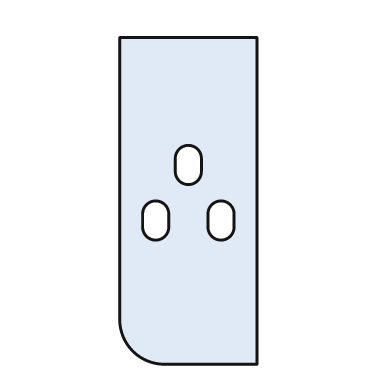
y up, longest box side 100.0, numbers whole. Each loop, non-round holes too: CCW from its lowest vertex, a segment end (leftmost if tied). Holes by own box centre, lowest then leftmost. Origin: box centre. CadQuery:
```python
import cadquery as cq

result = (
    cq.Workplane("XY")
    .moveTo(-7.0, -50.0)
    .lineTo(21.0, -50.0)
    .lineTo(21.0, 50.0)
    .lineTo(-21.0, 50.0)
    .lineTo(-21.0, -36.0)
    .threePointArc((-17.0, -46.0), (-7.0, -50.0))
    .close()
    .moveTo(-14.0, -8.0)
    .threePointArc((-10.0, -12.0), (-6.0, -8.0))
    .lineTo(-6.0, -4.0)
    .threePointArc((-10.0, 0.0), (-14.0, -4.0))
    .close()
    .moveTo(6.0, -8.0)
    .threePointArc((10.0, -12.0), (14.0, -8.0))
    .lineTo(14.0, -4.0)
    .threePointArc((10.0, 0.0), (6.0, -4.0))
    .close()
    .moveTo(-4.0, 9.0)
    .threePointArc((0.0, 5.0), (4.0, 9.0))
    .lineTo(4.0, 13.0)
    .threePointArc((0.0, 17.0), (-4.0, 13.0))
    .close()
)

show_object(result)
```